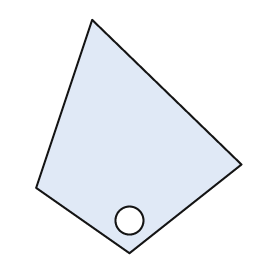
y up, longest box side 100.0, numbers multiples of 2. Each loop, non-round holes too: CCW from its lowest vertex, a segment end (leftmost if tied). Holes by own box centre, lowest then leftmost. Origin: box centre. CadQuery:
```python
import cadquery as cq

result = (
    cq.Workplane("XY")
    .moveTo(-4.0, -50.0)
    .lineTo(44.0, -12.0)
    .lineTo(-20.0, 50.0)
    .lineTo(-44.0, -22.0)
    .close()
    .moveTo(-4.0, -36.0)
    .circle(6.0)
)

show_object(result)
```